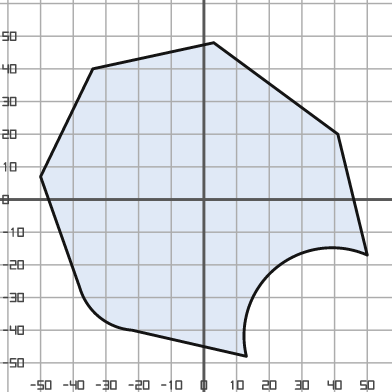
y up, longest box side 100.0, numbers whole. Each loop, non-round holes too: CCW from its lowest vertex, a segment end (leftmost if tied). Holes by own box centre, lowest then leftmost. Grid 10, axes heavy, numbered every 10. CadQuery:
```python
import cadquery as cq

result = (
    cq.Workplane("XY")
    .moveTo(13.0, -48.0)
    .threePointArc((22.0, -21.0), (50.0, -17.0))
    .lineTo(41.0, 20.0)
    .lineTo(3.0, 48.0)
    .lineTo(-34.0, 40.0)
    .lineTo(-50.0, 7.0)
    .lineTo(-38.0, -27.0)
    .threePointArc((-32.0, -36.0), (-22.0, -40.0))
    .close()
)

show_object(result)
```